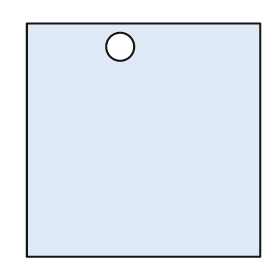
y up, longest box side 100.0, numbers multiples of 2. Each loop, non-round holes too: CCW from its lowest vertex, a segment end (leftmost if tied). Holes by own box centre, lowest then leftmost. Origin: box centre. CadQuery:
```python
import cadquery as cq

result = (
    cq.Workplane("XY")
    .moveTo(-50.0, -50.0)
    .lineTo(50.0, -50.0)
    .lineTo(50.0, 50.0)
    .lineTo(-50.0, 50.0)
    .close()
    .moveTo(-10.0, 40.0)
    .circle(6.0)
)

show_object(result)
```